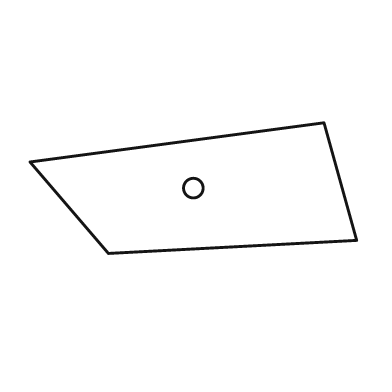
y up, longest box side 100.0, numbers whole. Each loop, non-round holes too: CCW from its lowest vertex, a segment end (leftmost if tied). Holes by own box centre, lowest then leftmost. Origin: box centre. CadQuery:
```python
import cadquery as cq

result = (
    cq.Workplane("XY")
    .moveTo(-26.0, -20.0)
    .lineTo(50.0, -16.0)
    .lineTo(40.0, 20.0)
    .lineTo(-50.0, 8.0)
    .close()
    .moveTo(0.0, 0.0)
    .circle(3.0)
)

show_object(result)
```